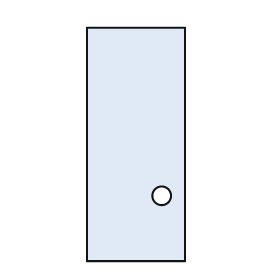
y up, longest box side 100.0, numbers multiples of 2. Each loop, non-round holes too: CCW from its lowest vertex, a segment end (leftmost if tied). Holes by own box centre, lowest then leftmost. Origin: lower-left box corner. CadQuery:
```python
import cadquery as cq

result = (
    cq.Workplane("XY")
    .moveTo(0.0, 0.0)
    .lineTo(42.0, 0.0)
    .lineTo(42.0, 100.0)
    .lineTo(0.0, 100.0)
    .close()
    .moveTo(32.0, 28.0)
    .circle(4.0)
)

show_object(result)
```